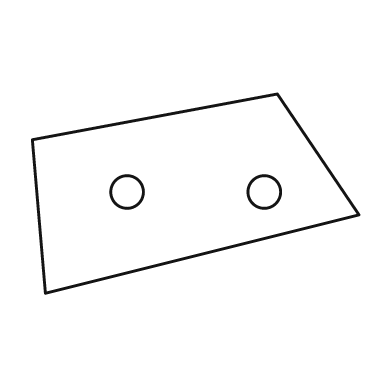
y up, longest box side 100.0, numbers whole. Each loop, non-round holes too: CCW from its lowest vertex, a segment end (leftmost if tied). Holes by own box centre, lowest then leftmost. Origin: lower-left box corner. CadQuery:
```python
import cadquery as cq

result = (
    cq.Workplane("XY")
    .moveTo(4.0, 0.0)
    .lineTo(100.0, 24.0)
    .lineTo(75.0, 61.0)
    .lineTo(0.0, 47.0)
    .close()
    .moveTo(29.0, 31.0)
    .circle(5.0)
    .moveTo(71.0, 31.0)
    .circle(5.0)
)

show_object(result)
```